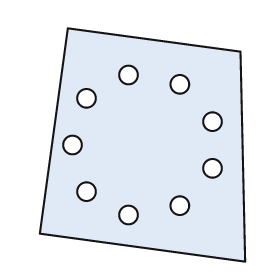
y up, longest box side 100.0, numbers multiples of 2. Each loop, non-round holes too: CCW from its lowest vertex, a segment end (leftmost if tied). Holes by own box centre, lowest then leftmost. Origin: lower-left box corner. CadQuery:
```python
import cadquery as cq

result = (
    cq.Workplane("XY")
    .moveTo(88.0, 0.0)
    .lineTo(86.0, 90.0)
    .lineTo(12.0, 100.0)
    .lineTo(0.0, 12.0)
    .close()
    .moveTo(38.0, 20.0)
    .circle(4.0)
    .moveTo(60.0, 24.0)
    .circle(4.0)
    .moveTo(20.0, 30.0)
    .circle(4.0)
    .moveTo(74.0, 40.0)
    .circle(4.0)
    .moveTo(14.0, 50.0)
    .circle(4.0)
    .moveTo(74.0, 60.0)
    .circle(4.0)
    .moveTo(20.0, 70.0)
    .circle(4.0)
    .moveTo(60.0, 76.0)
    .circle(4.0)
    .moveTo(38.0, 80.0)
    .circle(4.0)
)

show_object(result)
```